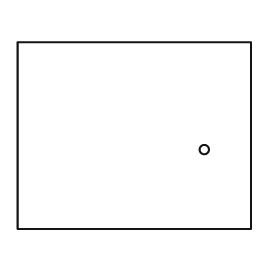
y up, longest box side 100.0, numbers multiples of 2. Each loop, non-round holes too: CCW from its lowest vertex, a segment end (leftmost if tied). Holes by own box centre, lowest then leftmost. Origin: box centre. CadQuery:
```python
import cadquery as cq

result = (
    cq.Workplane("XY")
    .moveTo(-50.0, -40.0)
    .lineTo(50.0, -40.0)
    .lineTo(50.0, 40.0)
    .lineTo(-50.0, 40.0)
    .close()
    .moveTo(30.0, -6.0)
    .circle(2.0)
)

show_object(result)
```